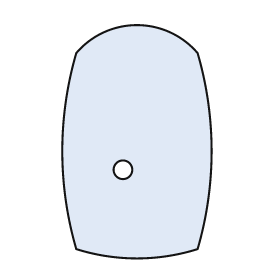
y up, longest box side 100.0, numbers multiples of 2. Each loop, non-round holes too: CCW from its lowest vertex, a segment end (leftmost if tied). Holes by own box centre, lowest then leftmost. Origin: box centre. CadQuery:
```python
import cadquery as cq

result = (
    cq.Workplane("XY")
    .moveTo(-26.0, -46.0)
    .threePointArc((0.0, -50.0), (26.0, -46.0))
    .threePointArc((32.0, -4.0), (26.0, 38.0))
    .threePointArc((0.0, 50.0), (-26.0, 38.0))
    .threePointArc((-32.0, -4.0), (-26.0, -46.0))
    .close()
    .moveTo(-6.0, -12.0)
    .circle(4.0)
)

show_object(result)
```